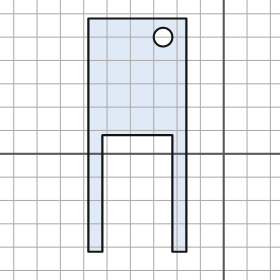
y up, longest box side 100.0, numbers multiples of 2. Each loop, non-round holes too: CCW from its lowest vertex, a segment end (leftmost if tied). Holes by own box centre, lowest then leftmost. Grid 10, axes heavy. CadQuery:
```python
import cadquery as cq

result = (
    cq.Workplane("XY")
    .moveTo(-58.0, -42.0)
    .lineTo(-52.0, -42.0)
    .lineTo(-52.0, 8.0)
    .lineTo(-22.0, 8.0)
    .lineTo(-22.0, -42.0)
    .lineTo(-16.0, -42.0)
    .lineTo(-16.0, 58.0)
    .lineTo(-58.0, 58.0)
    .close()
    .moveTo(-26.0, 50.0)
    .circle(4.0)
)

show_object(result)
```